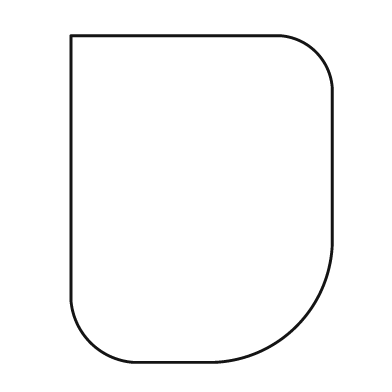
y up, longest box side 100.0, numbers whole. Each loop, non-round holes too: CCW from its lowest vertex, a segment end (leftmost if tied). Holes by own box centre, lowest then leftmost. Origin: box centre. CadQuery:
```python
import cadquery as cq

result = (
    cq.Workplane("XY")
    .moveTo(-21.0, -50.0)
    .lineTo(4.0, -50.0)
    .threePointArc((29.0, -39.0), (40.0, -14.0))
    .lineTo(40.0, 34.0)
    .threePointArc((35.0, 45.0), (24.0, 50.0))
    .lineTo(-40.0, 50.0)
    .lineTo(-40.0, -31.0)
    .threePointArc((-34.0, -44.0), (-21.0, -50.0))
    .close()
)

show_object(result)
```